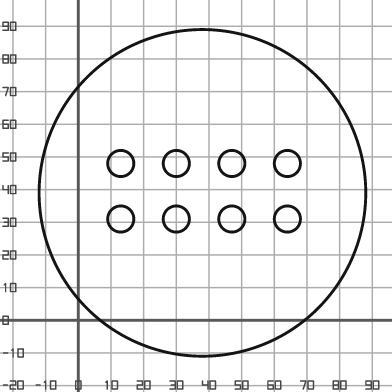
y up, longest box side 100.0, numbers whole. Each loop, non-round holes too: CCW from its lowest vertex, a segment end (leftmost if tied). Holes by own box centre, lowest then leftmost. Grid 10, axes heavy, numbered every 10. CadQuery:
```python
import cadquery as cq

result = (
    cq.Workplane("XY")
    .moveTo(38.0, 39.0)
    .circle(50.0)
    .moveTo(13.0, 31.0)
    .circle(4.0)
    .moveTo(30.0, 31.0)
    .circle(4.0)
    .moveTo(47.0, 31.0)
    .circle(4.0)
    .moveTo(64.0, 31.0)
    .circle(4.0)
    .moveTo(13.0, 48.0)
    .circle(4.0)
    .moveTo(30.0, 48.0)
    .circle(4.0)
    .moveTo(47.0, 48.0)
    .circle(4.0)
    .moveTo(64.0, 48.0)
    .circle(4.0)
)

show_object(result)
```